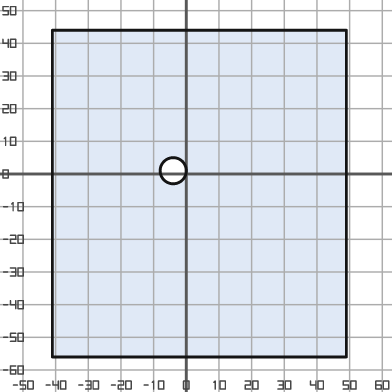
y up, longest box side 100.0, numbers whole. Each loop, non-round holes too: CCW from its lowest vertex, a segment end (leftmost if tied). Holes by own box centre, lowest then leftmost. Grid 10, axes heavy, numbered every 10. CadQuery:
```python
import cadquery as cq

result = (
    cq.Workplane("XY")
    .moveTo(-41.0, -56.0)
    .lineTo(49.0, -56.0)
    .lineTo(49.0, 44.0)
    .lineTo(-41.0, 44.0)
    .close()
    .moveTo(-4.0, 1.0)
    .circle(4.0)
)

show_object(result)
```